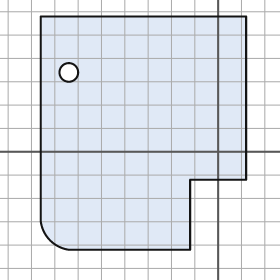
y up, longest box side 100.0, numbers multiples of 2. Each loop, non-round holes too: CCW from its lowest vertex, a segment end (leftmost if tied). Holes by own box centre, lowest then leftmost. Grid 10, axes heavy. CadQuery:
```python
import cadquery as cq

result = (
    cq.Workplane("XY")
    .moveTo(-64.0, -42.0)
    .lineTo(-12.0, -42.0)
    .lineTo(-12.0, -12.0)
    .lineTo(12.0, -12.0)
    .lineTo(12.0, 58.0)
    .lineTo(-76.0, 58.0)
    .lineTo(-76.0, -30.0)
    .threePointArc((-72.0, -38.0), (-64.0, -42.0))
    .close()
    .moveTo(-64.0, 34.0)
    .circle(4.0)
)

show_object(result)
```